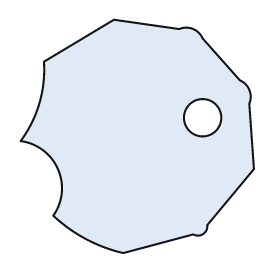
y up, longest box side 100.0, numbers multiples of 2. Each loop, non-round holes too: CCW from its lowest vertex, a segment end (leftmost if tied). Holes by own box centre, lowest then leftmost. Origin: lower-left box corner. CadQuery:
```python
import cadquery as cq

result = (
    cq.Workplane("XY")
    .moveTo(44.0, 0.0)
    .lineTo(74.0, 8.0)
    .threePointArc((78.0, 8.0), (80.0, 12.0))
    .lineTo(100.0, 36.0)
    .lineTo(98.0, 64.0)
    .threePointArc((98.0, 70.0), (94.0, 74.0))
    .lineTo(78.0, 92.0)
    .threePointArc((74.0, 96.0), (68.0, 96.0))
    .lineTo(40.0, 100.0)
    .lineTo(10.0, 82.0)
    .threePointArc((8.0, 64.0), (0.0, 48.0))
    .threePointArc((16.0, 36.0), (14.0, 16.0))
    .threePointArc((28.0, 6.0), (44.0, 0.0))
    .close()
    .moveTo(78.0, 58.0)
    .circle(8.0)
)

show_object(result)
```